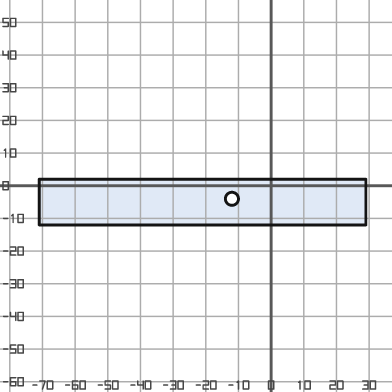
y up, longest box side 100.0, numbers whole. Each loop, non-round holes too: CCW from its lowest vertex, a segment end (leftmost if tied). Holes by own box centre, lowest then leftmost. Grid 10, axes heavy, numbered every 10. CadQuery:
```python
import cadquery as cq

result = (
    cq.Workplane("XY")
    .moveTo(-71.0, -12.0)
    .lineTo(29.0, -12.0)
    .lineTo(29.0, 2.0)
    .lineTo(-71.0, 2.0)
    .close()
    .moveTo(-12.0, -4.0)
    .circle(2.0)
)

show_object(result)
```